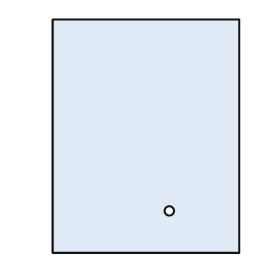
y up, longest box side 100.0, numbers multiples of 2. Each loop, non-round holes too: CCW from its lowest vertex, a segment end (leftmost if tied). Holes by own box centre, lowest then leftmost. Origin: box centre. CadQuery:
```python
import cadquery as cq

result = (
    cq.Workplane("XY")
    .moveTo(-40.0, -50.0)
    .lineTo(40.0, -50.0)
    .lineTo(40.0, 50.0)
    .lineTo(-40.0, 50.0)
    .close()
    .moveTo(10.0, -32.0)
    .circle(2.0)
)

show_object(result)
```